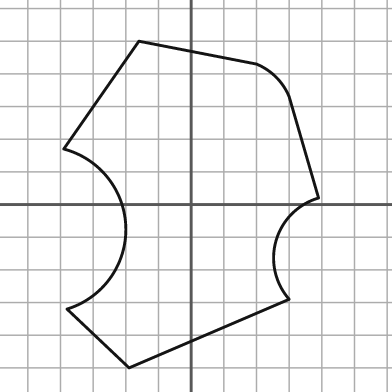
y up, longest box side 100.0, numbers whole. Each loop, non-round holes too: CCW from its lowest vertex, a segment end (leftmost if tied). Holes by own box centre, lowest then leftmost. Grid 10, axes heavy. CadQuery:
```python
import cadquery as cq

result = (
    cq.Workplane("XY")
    .moveTo(-19.0, -50.0)
    .lineTo(30.0, -29.0)
    .threePointArc((26.0, -11.0), (39.0, 2.0))
    .lineTo(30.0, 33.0)
    .threePointArc((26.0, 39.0), (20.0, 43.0))
    .lineTo(-16.0, 50.0)
    .lineTo(-39.0, 17.0)
    .threePointArc((-20.0, -7.0), (-38.0, -32.0))
    .close()
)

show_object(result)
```